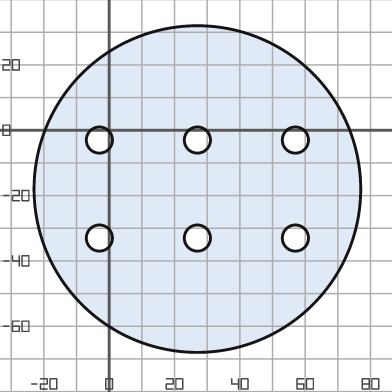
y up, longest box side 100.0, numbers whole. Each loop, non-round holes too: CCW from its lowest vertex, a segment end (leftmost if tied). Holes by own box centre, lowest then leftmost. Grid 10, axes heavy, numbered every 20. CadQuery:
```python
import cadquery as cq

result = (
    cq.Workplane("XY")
    .moveTo(27.0, -18.0)
    .circle(50.0)
    .moveTo(-3.0, -33.0)
    .circle(4.0)
    .moveTo(27.0, -33.0)
    .circle(4.0)
    .moveTo(57.0, -33.0)
    .circle(4.0)
    .moveTo(-3.0, -3.0)
    .circle(4.0)
    .moveTo(27.0, -3.0)
    .circle(4.0)
    .moveTo(57.0, -3.0)
    .circle(4.0)
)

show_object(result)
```